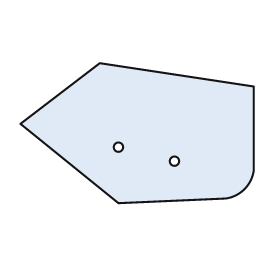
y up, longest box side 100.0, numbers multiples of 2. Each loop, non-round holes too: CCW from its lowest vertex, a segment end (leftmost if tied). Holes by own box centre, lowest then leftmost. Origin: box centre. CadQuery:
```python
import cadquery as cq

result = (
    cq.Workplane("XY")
    .moveTo(-8.0, -30.0)
    .lineTo(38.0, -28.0)
    .threePointArc((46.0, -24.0), (50.0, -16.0))
    .lineTo(50.0, 20.0)
    .lineTo(-16.0, 30.0)
    .lineTo(-50.0, 4.0)
    .close()
    .moveTo(16.0, -12.0)
    .circle(2.0)
    .moveTo(-8.0, -6.0)
    .circle(2.0)
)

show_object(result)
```